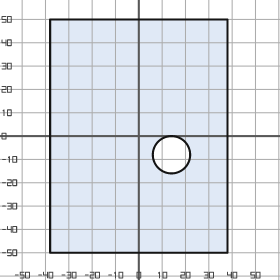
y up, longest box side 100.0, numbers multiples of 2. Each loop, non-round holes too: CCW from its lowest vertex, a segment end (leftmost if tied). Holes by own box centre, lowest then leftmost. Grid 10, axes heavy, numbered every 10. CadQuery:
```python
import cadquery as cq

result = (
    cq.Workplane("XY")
    .moveTo(-38.0, -50.0)
    .lineTo(38.0, -50.0)
    .lineTo(38.0, 50.0)
    .lineTo(-38.0, 50.0)
    .close()
    .moveTo(14.0, -8.0)
    .circle(8.0)
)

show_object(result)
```